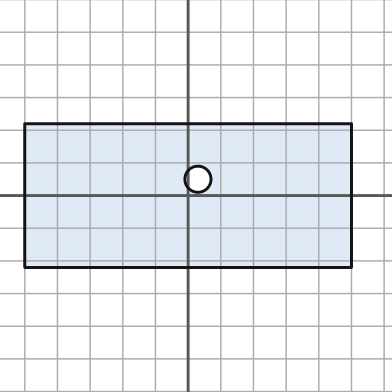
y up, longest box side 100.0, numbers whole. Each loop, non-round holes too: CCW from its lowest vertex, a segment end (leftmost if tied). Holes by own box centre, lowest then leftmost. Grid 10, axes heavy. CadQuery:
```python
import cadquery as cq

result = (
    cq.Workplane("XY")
    .moveTo(-50.0, -22.0)
    .lineTo(50.0, -22.0)
    .lineTo(50.0, 22.0)
    .lineTo(-50.0, 22.0)
    .close()
    .moveTo(3.0, 5.0)
    .circle(4.0)
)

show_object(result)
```